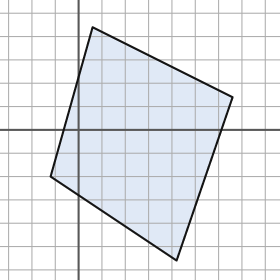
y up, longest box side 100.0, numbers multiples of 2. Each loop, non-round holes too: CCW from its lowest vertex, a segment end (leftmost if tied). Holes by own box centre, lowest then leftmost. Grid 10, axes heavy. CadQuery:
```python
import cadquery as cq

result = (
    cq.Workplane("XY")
    .moveTo(42.0, -56.0)
    .lineTo(66.0, 14.0)
    .lineTo(6.0, 44.0)
    .lineTo(-12.0, -20.0)
    .close()
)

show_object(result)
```